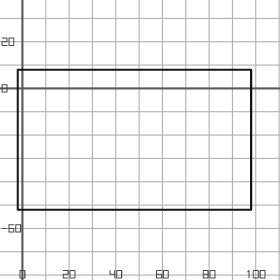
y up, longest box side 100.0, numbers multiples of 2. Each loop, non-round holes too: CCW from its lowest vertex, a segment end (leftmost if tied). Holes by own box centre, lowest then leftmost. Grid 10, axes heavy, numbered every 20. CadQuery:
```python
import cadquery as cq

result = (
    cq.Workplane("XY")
    .moveTo(-2.0, -52.0)
    .lineTo(98.0, -52.0)
    .lineTo(98.0, 8.0)
    .lineTo(-2.0, 8.0)
    .close()
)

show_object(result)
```